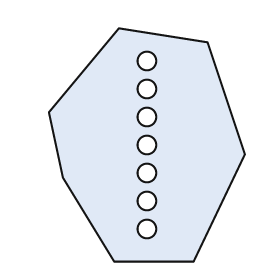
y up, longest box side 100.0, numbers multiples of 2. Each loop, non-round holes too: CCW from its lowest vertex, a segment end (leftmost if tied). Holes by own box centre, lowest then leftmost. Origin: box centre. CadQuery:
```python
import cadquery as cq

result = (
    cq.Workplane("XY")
    .moveTo(-14.0, -50.0)
    .lineTo(20.0, -50.0)
    .lineTo(42.0, -4.0)
    .lineTo(26.0, 44.0)
    .lineTo(-12.0, 50.0)
    .lineTo(-42.0, 14.0)
    .lineTo(-36.0, -14.0)
    .close()
    .moveTo(0.0, -36.0)
    .circle(4.0)
    .moveTo(0.0, -24.0)
    .circle(4.0)
    .moveTo(0.0, -12.0)
    .circle(4.0)
    .moveTo(0.0, 0.0)
    .circle(4.0)
    .moveTo(0.0, 12.0)
    .circle(4.0)
    .moveTo(0.0, 24.0)
    .circle(4.0)
    .moveTo(0.0, 36.0)
    .circle(4.0)
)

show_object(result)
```